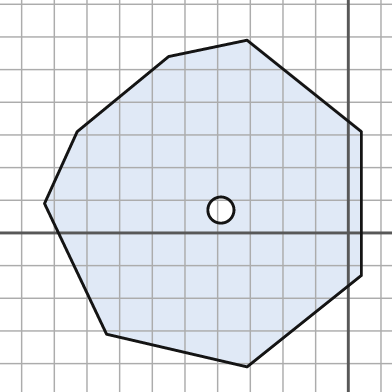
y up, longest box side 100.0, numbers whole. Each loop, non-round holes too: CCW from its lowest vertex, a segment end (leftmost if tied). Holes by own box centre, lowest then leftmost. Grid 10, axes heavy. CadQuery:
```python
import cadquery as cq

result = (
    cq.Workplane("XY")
    .moveTo(-31.0, -41.0)
    .lineTo(4.0, -13.0)
    .lineTo(4.0, 31.0)
    .lineTo(-31.0, 59.0)
    .lineTo(-55.0, 54.0)
    .lineTo(-83.0, 31.0)
    .lineTo(-93.0, 9.0)
    .lineTo(-74.0, -31.0)
    .close()
    .moveTo(-39.0, 7.0)
    .circle(4.0)
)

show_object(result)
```